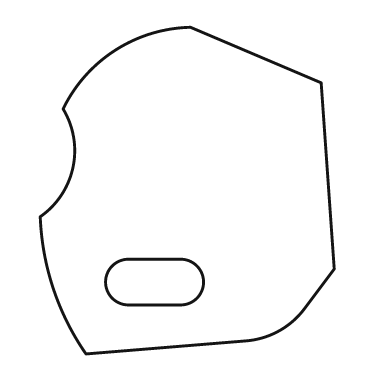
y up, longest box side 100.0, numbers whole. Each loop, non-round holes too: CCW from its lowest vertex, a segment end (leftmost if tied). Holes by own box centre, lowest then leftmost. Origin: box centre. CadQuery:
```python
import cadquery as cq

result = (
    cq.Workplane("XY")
    .moveTo(-31.0, -50.0)
    .lineTo(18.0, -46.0)
    .threePointArc((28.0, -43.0), (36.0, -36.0))
    .lineTo(45.0, -24.0)
    .lineTo(41.0, 33.0)
    .lineTo(1.0, 50.0)
    .threePointArc((-22.0, 43.0), (-38.0, 25.0))
    .threePointArc((-35.0, 7.0), (-45.0, -8.0))
    .threePointArc((-41.0, -30.0), (-31.0, -50.0))
    .close()
    .moveTo(-18.0, -35.0)
    .lineTo(-2.0, -35.0)
    .threePointArc((5.0, -28.0), (-2.0, -21.0))
    .lineTo(-18.0, -21.0)
    .threePointArc((-25.0, -28.0), (-18.0, -35.0))
    .close()
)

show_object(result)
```